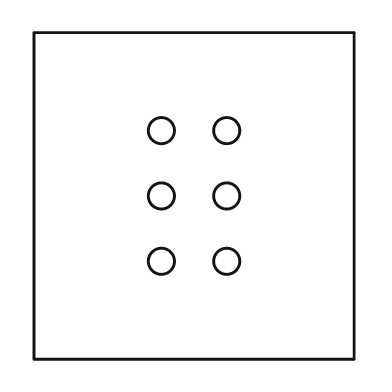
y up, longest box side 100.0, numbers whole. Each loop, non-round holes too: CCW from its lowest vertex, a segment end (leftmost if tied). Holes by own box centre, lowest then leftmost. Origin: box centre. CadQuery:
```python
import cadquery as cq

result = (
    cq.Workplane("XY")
    .moveTo(-49.0, -50.0)
    .lineTo(49.0, -50.0)
    .lineTo(49.0, 50.0)
    .lineTo(-49.0, 50.0)
    .close()
    .moveTo(-10.0, -20.0)
    .circle(4.0)
    .moveTo(10.0, -20.0)
    .circle(4.0)
    .moveTo(-10.0, 0.0)
    .circle(4.0)
    .moveTo(10.0, 0.0)
    .circle(4.0)
    .moveTo(-10.0, 20.0)
    .circle(4.0)
    .moveTo(10.0, 20.0)
    .circle(4.0)
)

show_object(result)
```